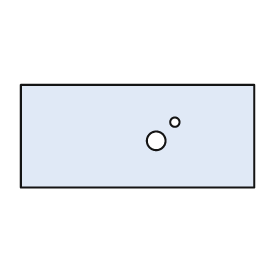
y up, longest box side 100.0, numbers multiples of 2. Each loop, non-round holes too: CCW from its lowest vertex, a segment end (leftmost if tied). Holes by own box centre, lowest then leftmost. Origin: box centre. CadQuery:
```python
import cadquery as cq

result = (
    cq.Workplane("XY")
    .moveTo(-50.0, -22.0)
    .lineTo(50.0, -22.0)
    .lineTo(50.0, 22.0)
    .lineTo(-50.0, 22.0)
    .close()
    .moveTo(8.0, -2.0)
    .circle(4.0)
    .moveTo(16.0, 6.0)
    .circle(2.0)
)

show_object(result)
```